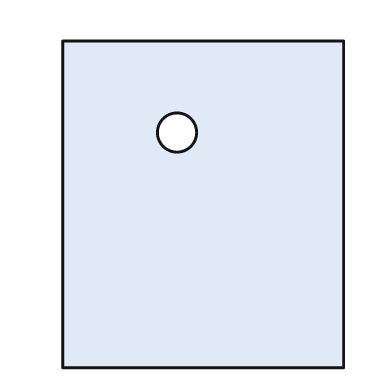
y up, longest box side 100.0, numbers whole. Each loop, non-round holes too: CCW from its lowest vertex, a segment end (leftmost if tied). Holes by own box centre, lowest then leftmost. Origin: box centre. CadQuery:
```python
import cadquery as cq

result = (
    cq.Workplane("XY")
    .moveTo(-43.0, -50.0)
    .lineTo(43.0, -50.0)
    .lineTo(43.0, 50.0)
    .lineTo(-43.0, 50.0)
    .close()
    .moveTo(-8.0, 22.0)
    .circle(6.0)
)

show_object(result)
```